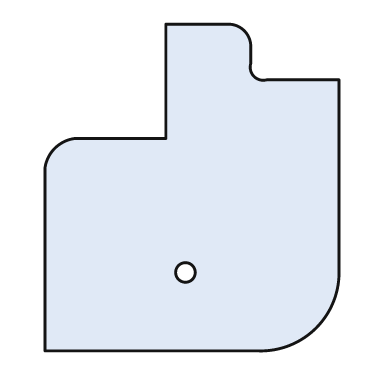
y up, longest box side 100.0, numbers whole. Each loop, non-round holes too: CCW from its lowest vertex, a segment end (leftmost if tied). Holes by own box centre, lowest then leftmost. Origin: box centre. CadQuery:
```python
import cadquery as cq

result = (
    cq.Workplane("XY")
    .moveTo(-45.0, -50.0)
    .lineTo(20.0, -50.0)
    .threePointArc((38.0, -43.0), (45.0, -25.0))
    .lineTo(45.0, 33.0)
    .lineTo(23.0, 33.0)
    .threePointArc((19.0, 34.0), (18.0, 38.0))
    .lineTo(18.0, 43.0)
    .threePointArc((16.0, 48.0), (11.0, 50.0))
    .lineTo(-8.0, 50.0)
    .lineTo(-8.0, 15.0)
    .lineTo(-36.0, 15.0)
    .threePointArc((-42.0, 12.0), (-45.0, 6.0))
    .close()
    .moveTo(-2.0, -26.0)
    .circle(3.0)
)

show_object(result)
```